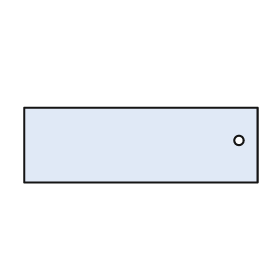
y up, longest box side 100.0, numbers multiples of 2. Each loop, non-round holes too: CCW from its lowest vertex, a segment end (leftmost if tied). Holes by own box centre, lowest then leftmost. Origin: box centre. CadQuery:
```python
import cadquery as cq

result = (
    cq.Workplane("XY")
    .moveTo(-50.0, -16.0)
    .lineTo(50.0, -16.0)
    .lineTo(50.0, 16.0)
    .lineTo(-50.0, 16.0)
    .close()
    .moveTo(42.0, 2.0)
    .circle(2.0)
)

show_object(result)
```